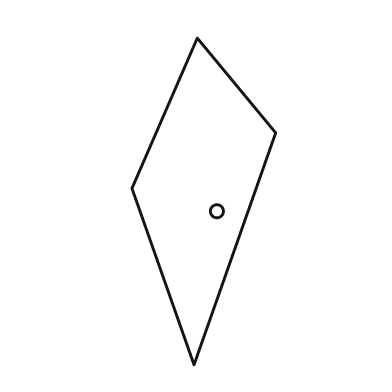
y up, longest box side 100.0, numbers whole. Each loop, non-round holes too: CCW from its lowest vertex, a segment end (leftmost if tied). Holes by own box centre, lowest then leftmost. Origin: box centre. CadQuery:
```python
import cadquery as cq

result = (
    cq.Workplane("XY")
    .moveTo(-3.0, -50.0)
    .lineTo(22.0, 21.0)
    .lineTo(-2.0, 50.0)
    .lineTo(-22.0, 4.0)
    .close()
    .moveTo(4.0, -3.0)
    .circle(2.0)
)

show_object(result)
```